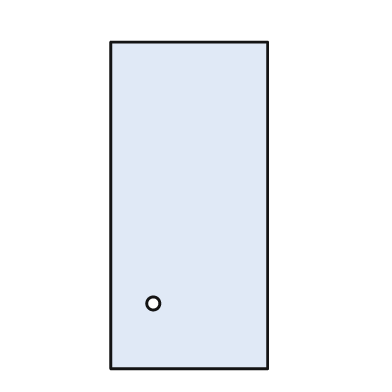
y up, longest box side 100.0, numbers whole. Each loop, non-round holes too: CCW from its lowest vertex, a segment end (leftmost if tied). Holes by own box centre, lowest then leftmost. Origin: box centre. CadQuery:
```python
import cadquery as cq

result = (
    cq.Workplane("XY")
    .moveTo(-24.0, -50.0)
    .lineTo(24.0, -50.0)
    .lineTo(24.0, 50.0)
    .lineTo(-24.0, 50.0)
    .close()
    .moveTo(-11.0, -30.0)
    .circle(2.0)
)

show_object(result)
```